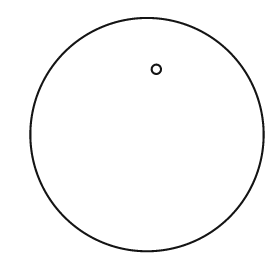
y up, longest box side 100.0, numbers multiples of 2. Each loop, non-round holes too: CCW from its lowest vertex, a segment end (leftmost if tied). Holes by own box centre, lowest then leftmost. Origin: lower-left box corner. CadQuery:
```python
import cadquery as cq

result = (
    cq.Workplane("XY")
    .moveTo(50.0, 50.0)
    .circle(50.0)
    .moveTo(54.0, 78.0)
    .circle(2.0)
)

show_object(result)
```